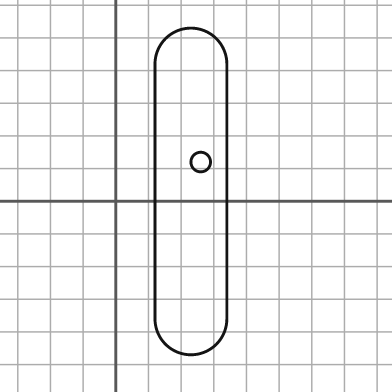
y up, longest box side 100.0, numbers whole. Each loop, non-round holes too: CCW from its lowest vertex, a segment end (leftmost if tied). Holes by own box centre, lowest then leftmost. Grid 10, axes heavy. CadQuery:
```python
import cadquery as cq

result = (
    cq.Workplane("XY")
    .moveTo(12.0, -36.0)
    .threePointArc((23.0, -47.0), (34.0, -36.0))
    .lineTo(34.0, 42.0)
    .threePointArc((23.0, 53.0), (12.0, 42.0))
    .close()
    .moveTo(26.0, 12.0)
    .circle(3.0)
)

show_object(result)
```